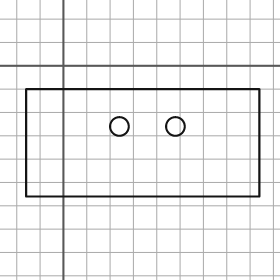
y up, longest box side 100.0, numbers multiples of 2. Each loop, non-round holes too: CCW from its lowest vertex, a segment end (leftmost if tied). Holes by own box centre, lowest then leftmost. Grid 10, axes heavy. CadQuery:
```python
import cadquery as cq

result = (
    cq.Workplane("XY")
    .moveTo(-16.0, -56.0)
    .lineTo(84.0, -56.0)
    .lineTo(84.0, -10.0)
    .lineTo(-16.0, -10.0)
    .close()
    .moveTo(24.0, -26.0)
    .circle(4.0)
    .moveTo(48.0, -26.0)
    .circle(4.0)
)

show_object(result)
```